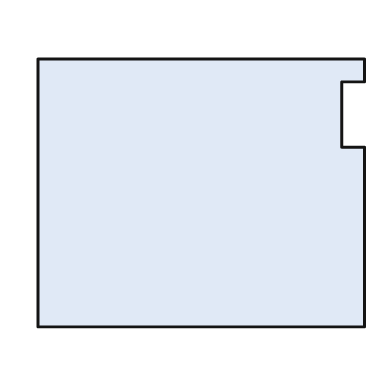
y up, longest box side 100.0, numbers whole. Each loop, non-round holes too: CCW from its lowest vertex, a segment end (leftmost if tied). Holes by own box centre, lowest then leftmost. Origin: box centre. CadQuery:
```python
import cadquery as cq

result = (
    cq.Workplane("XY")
    .moveTo(-50.0, -41.0)
    .lineTo(50.0, -41.0)
    .lineTo(50.0, 14.0)
    .lineTo(43.0, 14.0)
    .lineTo(43.0, 34.0)
    .lineTo(50.0, 34.0)
    .lineTo(50.0, 41.0)
    .lineTo(-50.0, 41.0)
    .close()
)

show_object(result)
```